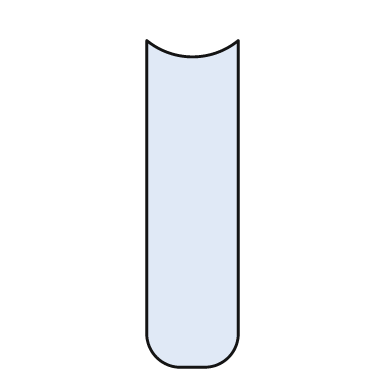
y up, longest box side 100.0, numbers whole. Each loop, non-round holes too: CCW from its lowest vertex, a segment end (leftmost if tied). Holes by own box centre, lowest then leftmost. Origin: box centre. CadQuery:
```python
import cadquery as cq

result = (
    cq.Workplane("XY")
    .moveTo(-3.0, -50.0)
    .lineTo(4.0, -50.0)
    .threePointArc((11.0, -47.0), (14.0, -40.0))
    .lineTo(14.0, 50.0)
    .threePointArc((0.0, 45.0), (-14.0, 50.0))
    .lineTo(-14.0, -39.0)
    .threePointArc((-11.0, -47.0), (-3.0, -50.0))
    .close()
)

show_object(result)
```